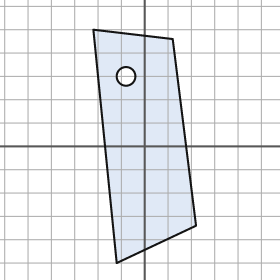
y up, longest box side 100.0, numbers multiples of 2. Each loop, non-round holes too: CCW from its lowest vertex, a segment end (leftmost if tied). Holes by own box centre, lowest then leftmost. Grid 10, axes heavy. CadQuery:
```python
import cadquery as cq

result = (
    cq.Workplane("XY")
    .moveTo(-12.0, -50.0)
    .lineTo(22.0, -34.0)
    .lineTo(12.0, 46.0)
    .lineTo(-22.0, 50.0)
    .close()
    .moveTo(-8.0, 30.0)
    .circle(4.0)
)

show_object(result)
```